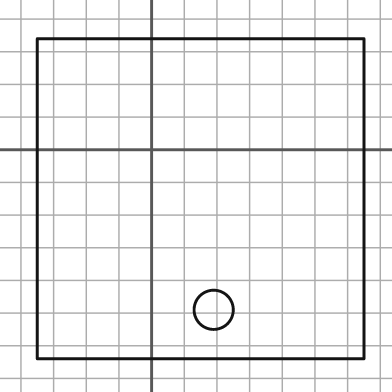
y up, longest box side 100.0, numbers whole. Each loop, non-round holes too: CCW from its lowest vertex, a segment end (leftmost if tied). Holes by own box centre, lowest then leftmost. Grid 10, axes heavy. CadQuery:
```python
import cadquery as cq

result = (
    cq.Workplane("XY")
    .moveTo(-35.0, -64.0)
    .lineTo(65.0, -64.0)
    .lineTo(65.0, 34.0)
    .lineTo(-35.0, 34.0)
    .close()
    .moveTo(19.0, -49.0)
    .circle(6.0)
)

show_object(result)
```